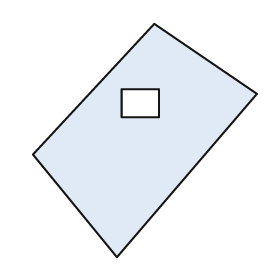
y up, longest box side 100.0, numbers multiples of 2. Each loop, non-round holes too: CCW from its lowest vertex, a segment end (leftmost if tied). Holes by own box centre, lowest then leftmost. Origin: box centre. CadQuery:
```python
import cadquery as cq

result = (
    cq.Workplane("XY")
    .moveTo(-12.0, -50.0)
    .lineTo(48.0, 20.0)
    .lineTo(4.0, 50.0)
    .lineTo(-48.0, -6.0)
    .close()
    .moveTo(-10.0, 10.0)
    .lineTo(6.0, 10.0)
    .lineTo(6.0, 22.0)
    .lineTo(-10.0, 22.0)
    .close()
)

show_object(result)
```